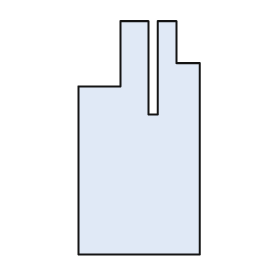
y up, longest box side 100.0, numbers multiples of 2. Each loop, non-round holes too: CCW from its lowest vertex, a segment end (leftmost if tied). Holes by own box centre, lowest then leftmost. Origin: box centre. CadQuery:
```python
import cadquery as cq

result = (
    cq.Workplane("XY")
    .moveTo(-26.0, -50.0)
    .lineTo(26.0, -50.0)
    .lineTo(26.0, 32.0)
    .lineTo(16.0, 32.0)
    .lineTo(16.0, 50.0)
    .lineTo(8.0, 50.0)
    .lineTo(8.0, 10.0)
    .lineTo(4.0, 10.0)
    .lineTo(4.0, 50.0)
    .lineTo(-8.0, 50.0)
    .lineTo(-8.0, 22.0)
    .lineTo(-26.0, 22.0)
    .close()
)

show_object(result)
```